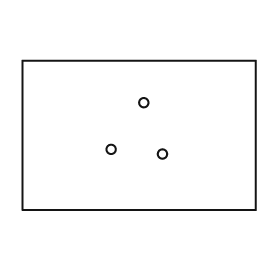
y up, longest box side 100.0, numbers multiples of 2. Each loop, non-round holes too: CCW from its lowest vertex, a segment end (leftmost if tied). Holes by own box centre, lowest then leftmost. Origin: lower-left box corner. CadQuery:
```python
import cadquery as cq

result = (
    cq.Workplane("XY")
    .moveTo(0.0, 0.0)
    .lineTo(100.0, 0.0)
    .lineTo(100.0, 64.0)
    .lineTo(0.0, 64.0)
    .close()
    .moveTo(60.0, 24.0)
    .circle(2.0)
    .moveTo(38.0, 26.0)
    .circle(2.0)
    .moveTo(52.0, 46.0)
    .circle(2.0)
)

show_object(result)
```